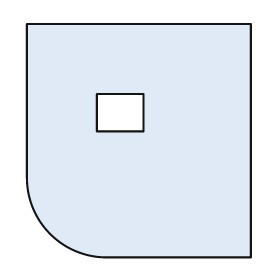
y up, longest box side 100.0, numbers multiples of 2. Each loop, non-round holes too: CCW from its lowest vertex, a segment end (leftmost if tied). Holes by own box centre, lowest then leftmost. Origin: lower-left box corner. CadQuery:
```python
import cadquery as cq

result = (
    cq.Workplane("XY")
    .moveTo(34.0, 0.0)
    .lineTo(96.0, 0.0)
    .lineTo(96.0, 100.0)
    .lineTo(0.0, 100.0)
    .lineTo(0.0, 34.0)
    .threePointArc((10.0, 10.0), (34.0, 0.0))
    .close()
    .moveTo(30.0, 54.0)
    .lineTo(50.0, 54.0)
    .lineTo(50.0, 70.0)
    .lineTo(30.0, 70.0)
    .close()
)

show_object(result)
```